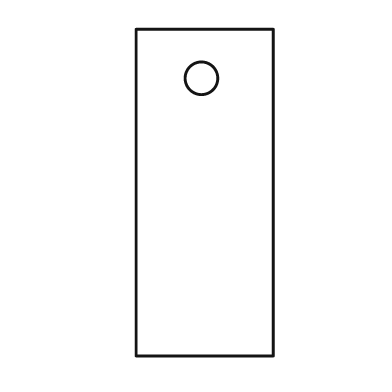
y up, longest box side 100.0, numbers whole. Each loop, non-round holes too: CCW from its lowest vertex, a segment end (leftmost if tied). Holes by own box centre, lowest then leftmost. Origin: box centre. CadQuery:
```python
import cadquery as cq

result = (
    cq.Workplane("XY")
    .moveTo(-21.0, -50.0)
    .lineTo(21.0, -50.0)
    .lineTo(21.0, 50.0)
    .lineTo(-21.0, 50.0)
    .close()
    .moveTo(-1.0, 35.0)
    .circle(5.0)
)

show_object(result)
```